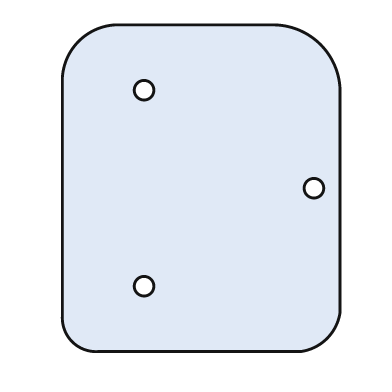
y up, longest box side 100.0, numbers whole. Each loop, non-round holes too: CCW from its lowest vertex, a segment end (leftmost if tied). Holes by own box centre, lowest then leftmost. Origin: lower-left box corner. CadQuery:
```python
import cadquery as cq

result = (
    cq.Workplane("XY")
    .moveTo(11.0, 0.0)
    .lineTo(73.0, 0.0)
    .threePointArc((81.0, 4.0), (85.0, 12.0))
    .lineTo(85.0, 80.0)
    .threePointArc((79.0, 94.0), (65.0, 100.0))
    .lineTo(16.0, 100.0)
    .threePointArc((5.0, 95.0), (0.0, 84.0))
    .lineTo(0.0, 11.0)
    .threePointArc((3.0, 3.0), (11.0, 0.0))
    .close()
    .moveTo(25.0, 20.0)
    .circle(3.0)
    .moveTo(77.0, 50.0)
    .circle(3.0)
    .moveTo(25.0, 80.0)
    .circle(3.0)
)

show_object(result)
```